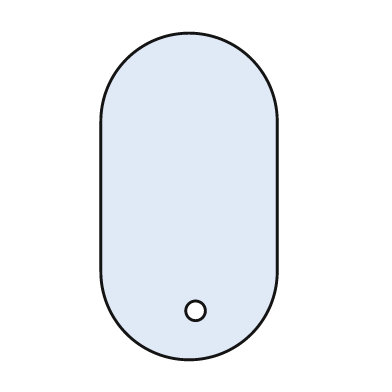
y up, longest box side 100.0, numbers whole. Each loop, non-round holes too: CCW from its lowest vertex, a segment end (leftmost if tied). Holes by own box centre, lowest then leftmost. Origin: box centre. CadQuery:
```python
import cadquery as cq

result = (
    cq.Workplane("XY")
    .moveTo(-27.0, -23.0)
    .threePointArc((0.0, -50.0), (27.0, -23.0))
    .lineTo(27.0, 23.0)
    .threePointArc((0.0, 50.0), (-27.0, 23.0))
    .close()
    .moveTo(2.0, -35.0)
    .circle(3.0)
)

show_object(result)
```